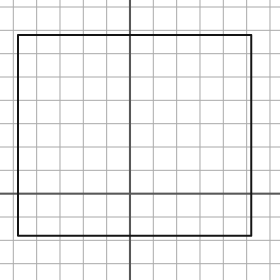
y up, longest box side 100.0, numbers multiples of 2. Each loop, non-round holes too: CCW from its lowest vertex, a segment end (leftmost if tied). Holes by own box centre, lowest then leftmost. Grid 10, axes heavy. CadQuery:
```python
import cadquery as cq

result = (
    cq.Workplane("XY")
    .moveTo(-48.0, -18.0)
    .lineTo(52.0, -18.0)
    .lineTo(52.0, 68.0)
    .lineTo(-48.0, 68.0)
    .close()
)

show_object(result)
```